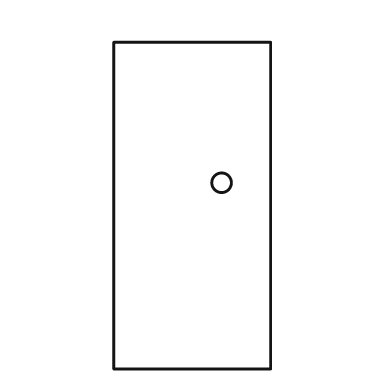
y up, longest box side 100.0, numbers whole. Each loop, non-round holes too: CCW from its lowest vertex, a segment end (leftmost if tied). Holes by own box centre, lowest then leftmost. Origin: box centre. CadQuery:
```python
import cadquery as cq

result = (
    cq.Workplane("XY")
    .moveTo(-24.0, -50.0)
    .lineTo(24.0, -50.0)
    .lineTo(24.0, 50.0)
    .lineTo(-24.0, 50.0)
    .close()
    .moveTo(9.0, 7.0)
    .circle(3.0)
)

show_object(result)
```